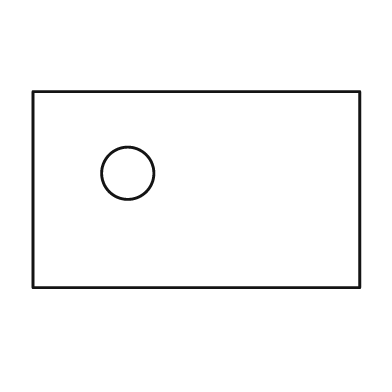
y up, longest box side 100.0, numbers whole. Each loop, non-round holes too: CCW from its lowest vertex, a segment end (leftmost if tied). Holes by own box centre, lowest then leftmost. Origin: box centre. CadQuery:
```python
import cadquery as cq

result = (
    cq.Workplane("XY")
    .moveTo(-50.0, -30.0)
    .lineTo(50.0, -30.0)
    .lineTo(50.0, 30.0)
    .lineTo(-50.0, 30.0)
    .close()
    .moveTo(-21.0, 5.0)
    .circle(8.0)
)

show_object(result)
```